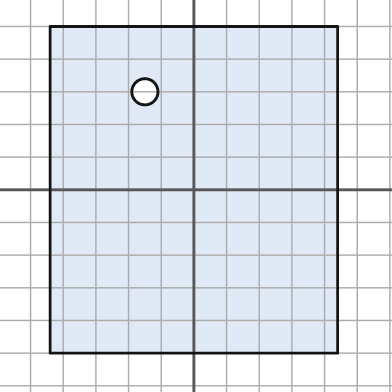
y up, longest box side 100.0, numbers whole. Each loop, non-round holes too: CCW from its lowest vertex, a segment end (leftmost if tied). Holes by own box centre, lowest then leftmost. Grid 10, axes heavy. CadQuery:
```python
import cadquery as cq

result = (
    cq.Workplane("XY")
    .moveTo(-44.0, -50.0)
    .lineTo(44.0, -50.0)
    .lineTo(44.0, 50.0)
    .lineTo(-44.0, 50.0)
    .close()
    .moveTo(-15.0, 30.0)
    .circle(4.0)
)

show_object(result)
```